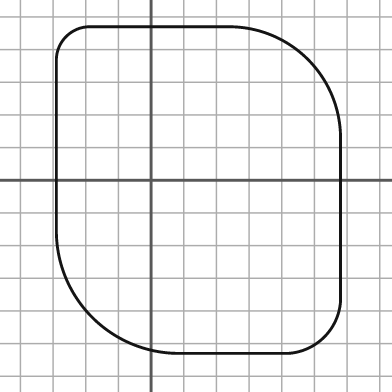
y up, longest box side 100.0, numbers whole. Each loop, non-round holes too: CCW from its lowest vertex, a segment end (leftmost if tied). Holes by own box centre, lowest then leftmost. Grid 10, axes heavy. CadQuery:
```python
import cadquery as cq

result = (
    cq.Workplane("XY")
    .moveTo(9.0, -53.0)
    .lineTo(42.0, -53.0)
    .threePointArc((53.0, -48.0), (58.0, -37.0))
    .lineTo(58.0, 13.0)
    .threePointArc((48.0, 37.0), (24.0, 47.0))
    .lineTo(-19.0, 47.0)
    .threePointArc((-26.0, 44.0), (-29.0, 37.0))
    .lineTo(-29.0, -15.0)
    .threePointArc((-18.0, -42.0), (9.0, -53.0))
    .close()
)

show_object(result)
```